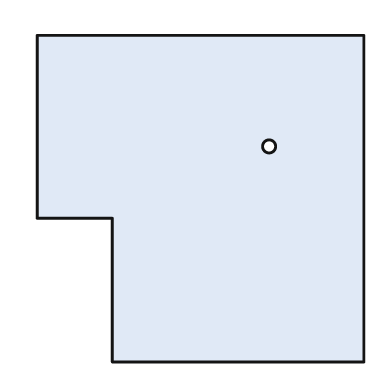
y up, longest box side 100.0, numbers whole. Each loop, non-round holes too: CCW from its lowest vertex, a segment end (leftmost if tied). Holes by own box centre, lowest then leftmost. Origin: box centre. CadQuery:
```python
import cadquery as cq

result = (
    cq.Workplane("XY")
    .moveTo(-27.0, -50.0)
    .lineTo(50.0, -50.0)
    .lineTo(50.0, 50.0)
    .lineTo(-50.0, 50.0)
    .lineTo(-50.0, -6.0)
    .lineTo(-27.0, -6.0)
    .close()
    .moveTo(21.0, 16.0)
    .circle(2.0)
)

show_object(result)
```